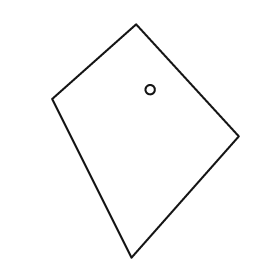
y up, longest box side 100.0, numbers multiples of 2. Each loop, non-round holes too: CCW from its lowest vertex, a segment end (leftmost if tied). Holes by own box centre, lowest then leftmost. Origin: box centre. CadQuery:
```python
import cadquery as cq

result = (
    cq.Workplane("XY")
    .moveTo(-6.0, -50.0)
    .lineTo(40.0, 2.0)
    .lineTo(-4.0, 50.0)
    .lineTo(-40.0, 18.0)
    .close()
    .moveTo(2.0, 22.0)
    .circle(2.0)
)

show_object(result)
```